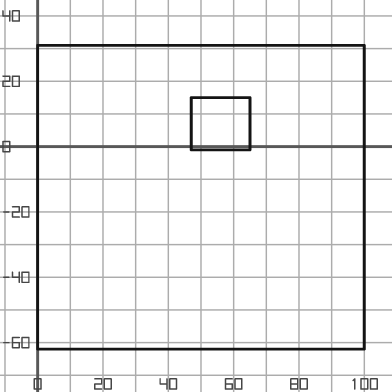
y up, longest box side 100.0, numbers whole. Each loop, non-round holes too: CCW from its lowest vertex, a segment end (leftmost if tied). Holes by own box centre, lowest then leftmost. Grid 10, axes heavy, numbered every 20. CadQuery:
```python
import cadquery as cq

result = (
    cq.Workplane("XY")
    .moveTo(0.0, -62.0)
    .lineTo(100.0, -62.0)
    .lineTo(100.0, 31.0)
    .lineTo(0.0, 31.0)
    .close()
    .moveTo(47.0, -1.0)
    .lineTo(65.0, -1.0)
    .lineTo(65.0, 15.0)
    .lineTo(47.0, 15.0)
    .close()
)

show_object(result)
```